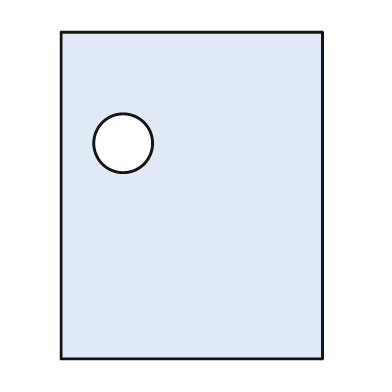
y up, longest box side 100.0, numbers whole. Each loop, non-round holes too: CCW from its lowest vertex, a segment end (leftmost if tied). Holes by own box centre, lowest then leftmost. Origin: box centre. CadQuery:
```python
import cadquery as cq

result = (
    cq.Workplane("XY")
    .moveTo(-40.0, -50.0)
    .lineTo(40.0, -50.0)
    .lineTo(40.0, 50.0)
    .lineTo(-40.0, 50.0)
    .close()
    .moveTo(-21.0, 16.0)
    .circle(9.0)
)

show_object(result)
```